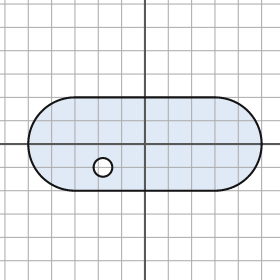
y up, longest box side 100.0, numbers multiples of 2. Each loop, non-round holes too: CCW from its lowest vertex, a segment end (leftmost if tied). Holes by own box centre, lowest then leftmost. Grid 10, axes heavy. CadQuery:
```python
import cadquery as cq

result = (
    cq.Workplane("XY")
    .moveTo(-30.0, -20.0)
    .lineTo(30.0, -20.0)
    .threePointArc((50.0, 0.0), (30.0, 20.0))
    .lineTo(-30.0, 20.0)
    .threePointArc((-50.0, 0.0), (-30.0, -20.0))
    .close()
    .moveTo(-18.0, -10.0)
    .circle(4.0)
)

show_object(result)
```